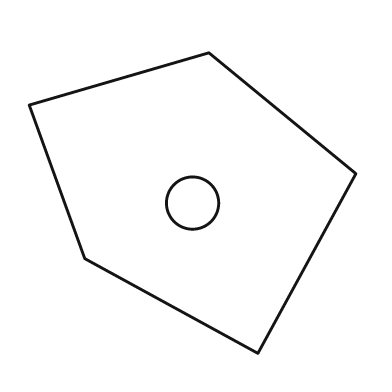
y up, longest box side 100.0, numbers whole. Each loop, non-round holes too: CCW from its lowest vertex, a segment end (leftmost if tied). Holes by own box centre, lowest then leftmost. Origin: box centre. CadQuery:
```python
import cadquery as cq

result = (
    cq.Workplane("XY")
    .moveTo(20.0, -46.0)
    .lineTo(50.0, 9.0)
    .lineTo(5.0, 46.0)
    .lineTo(-50.0, 30.0)
    .lineTo(-33.0, -17.0)
    .close()
    .moveTo(0.0, 0.0)
    .circle(8.0)
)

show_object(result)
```